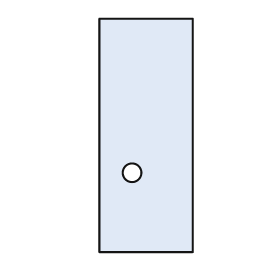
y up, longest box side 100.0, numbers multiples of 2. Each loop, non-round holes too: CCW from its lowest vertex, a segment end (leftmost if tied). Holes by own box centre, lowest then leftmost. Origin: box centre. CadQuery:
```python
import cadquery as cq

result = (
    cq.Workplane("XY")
    .moveTo(-20.0, -50.0)
    .lineTo(20.0, -50.0)
    .lineTo(20.0, 50.0)
    .lineTo(-20.0, 50.0)
    .close()
    .moveTo(-6.0, -16.0)
    .circle(4.0)
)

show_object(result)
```